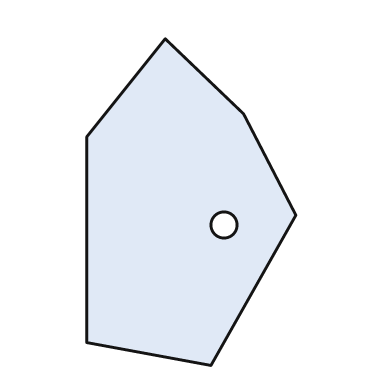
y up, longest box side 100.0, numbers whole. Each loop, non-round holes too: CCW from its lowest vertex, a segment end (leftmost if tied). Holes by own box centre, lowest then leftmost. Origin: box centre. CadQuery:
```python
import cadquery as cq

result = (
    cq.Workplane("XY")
    .moveTo(6.0, -50.0)
    .lineTo(32.0, -4.0)
    .lineTo(16.0, 27.0)
    .lineTo(-8.0, 50.0)
    .lineTo(-32.0, 20.0)
    .lineTo(-32.0, -43.0)
    .close()
    .moveTo(10.0, -7.0)
    .circle(4.0)
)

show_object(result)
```